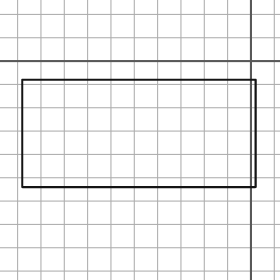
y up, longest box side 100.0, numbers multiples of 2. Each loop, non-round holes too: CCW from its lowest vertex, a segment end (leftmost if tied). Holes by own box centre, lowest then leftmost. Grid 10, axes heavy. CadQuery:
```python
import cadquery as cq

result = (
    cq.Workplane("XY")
    .moveTo(-98.0, -54.0)
    .lineTo(2.0, -54.0)
    .lineTo(2.0, -8.0)
    .lineTo(-98.0, -8.0)
    .close()
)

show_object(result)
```